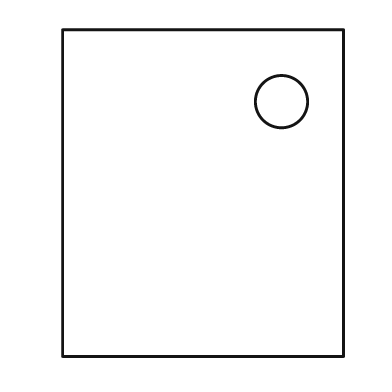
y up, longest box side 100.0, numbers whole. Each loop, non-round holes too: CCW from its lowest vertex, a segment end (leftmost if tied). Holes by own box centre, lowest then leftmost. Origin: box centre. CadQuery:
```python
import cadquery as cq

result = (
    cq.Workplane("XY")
    .moveTo(-43.0, -50.0)
    .lineTo(43.0, -50.0)
    .lineTo(43.0, 50.0)
    .lineTo(-43.0, 50.0)
    .close()
    .moveTo(24.0, 28.0)
    .circle(8.0)
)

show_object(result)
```